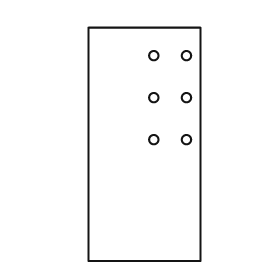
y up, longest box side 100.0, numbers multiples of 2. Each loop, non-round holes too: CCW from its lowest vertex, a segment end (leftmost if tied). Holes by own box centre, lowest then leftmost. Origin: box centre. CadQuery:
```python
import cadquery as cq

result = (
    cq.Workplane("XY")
    .moveTo(-24.0, -50.0)
    .lineTo(24.0, -50.0)
    .lineTo(24.0, 50.0)
    .lineTo(-24.0, 50.0)
    .close()
    .moveTo(4.0, 2.0)
    .circle(2.0)
    .moveTo(18.0, 2.0)
    .circle(2.0)
    .moveTo(4.0, 20.0)
    .circle(2.0)
    .moveTo(18.0, 20.0)
    .circle(2.0)
    .moveTo(4.0, 38.0)
    .circle(2.0)
    .moveTo(18.0, 38.0)
    .circle(2.0)
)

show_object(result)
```